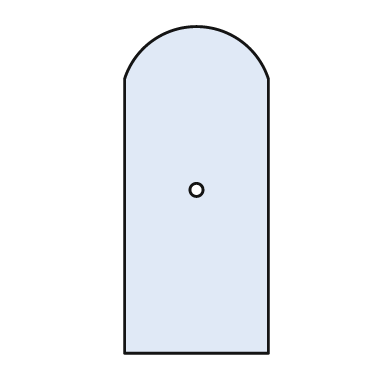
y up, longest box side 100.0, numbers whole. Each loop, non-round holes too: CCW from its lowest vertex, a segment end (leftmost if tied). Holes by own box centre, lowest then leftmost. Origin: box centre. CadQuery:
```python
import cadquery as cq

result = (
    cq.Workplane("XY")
    .moveTo(-22.0, -50.0)
    .lineTo(22.0, -50.0)
    .lineTo(22.0, 34.0)
    .threePointArc((0.0, 50.0), (-22.0, 34.0))
    .close()
    .moveTo(0.0, 0.0)
    .circle(2.0)
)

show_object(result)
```